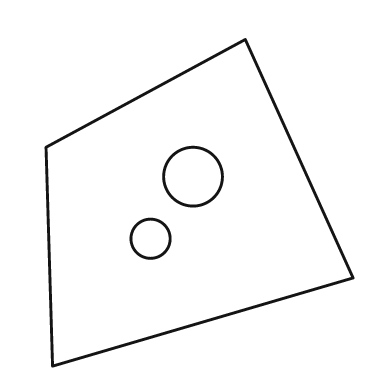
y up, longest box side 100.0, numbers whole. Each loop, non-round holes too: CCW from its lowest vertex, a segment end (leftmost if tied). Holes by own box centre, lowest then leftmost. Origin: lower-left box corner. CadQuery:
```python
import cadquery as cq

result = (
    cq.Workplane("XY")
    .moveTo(2.0, 0.0)
    .lineTo(94.0, 27.0)
    .lineTo(61.0, 100.0)
    .lineTo(0.0, 67.0)
    .close()
    .moveTo(32.0, 39.0)
    .circle(6.0)
    .moveTo(45.0, 58.0)
    .circle(9.0)
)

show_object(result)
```